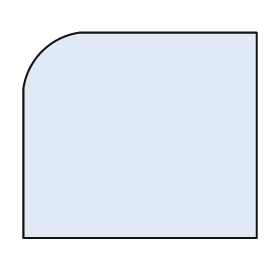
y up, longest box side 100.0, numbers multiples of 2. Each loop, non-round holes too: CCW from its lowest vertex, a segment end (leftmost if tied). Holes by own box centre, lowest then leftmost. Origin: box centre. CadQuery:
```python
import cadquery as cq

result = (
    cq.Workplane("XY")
    .moveTo(-50.0, -44.0)
    .lineTo(50.0, -44.0)
    .lineTo(50.0, 44.0)
    .lineTo(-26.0, 44.0)
    .threePointArc((-42.0, 36.0), (-50.0, 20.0))
    .close()
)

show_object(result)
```